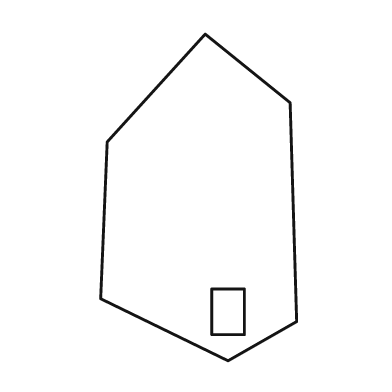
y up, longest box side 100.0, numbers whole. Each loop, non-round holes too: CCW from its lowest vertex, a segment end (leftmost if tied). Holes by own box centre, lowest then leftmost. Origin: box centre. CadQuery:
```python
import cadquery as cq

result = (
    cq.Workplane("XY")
    .moveTo(9.0, -50.0)
    .lineTo(30.0, -38.0)
    .lineTo(28.0, 29.0)
    .lineTo(2.0, 50.0)
    .lineTo(-28.0, 17.0)
    .lineTo(-30.0, -31.0)
    .close()
    .moveTo(4.0, -42.0)
    .lineTo(14.0, -42.0)
    .lineTo(14.0, -28.0)
    .lineTo(4.0, -28.0)
    .close()
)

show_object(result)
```